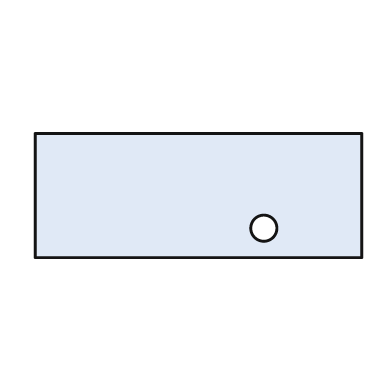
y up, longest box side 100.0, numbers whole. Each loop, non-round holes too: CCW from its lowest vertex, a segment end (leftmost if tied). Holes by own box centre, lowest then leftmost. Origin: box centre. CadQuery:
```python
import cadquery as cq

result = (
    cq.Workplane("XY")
    .moveTo(-50.0, -19.0)
    .lineTo(50.0, -19.0)
    .lineTo(50.0, 19.0)
    .lineTo(-50.0, 19.0)
    .close()
    .moveTo(20.0, -10.0)
    .circle(4.0)
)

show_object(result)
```